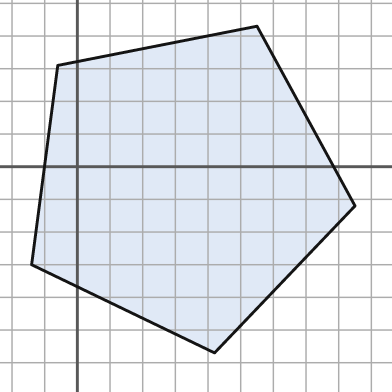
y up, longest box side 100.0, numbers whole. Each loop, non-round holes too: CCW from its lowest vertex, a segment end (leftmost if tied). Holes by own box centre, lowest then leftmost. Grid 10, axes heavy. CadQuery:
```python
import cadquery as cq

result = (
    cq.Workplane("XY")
    .moveTo(42.0, -57.0)
    .lineTo(85.0, -12.0)
    .lineTo(55.0, 43.0)
    .lineTo(-6.0, 31.0)
    .lineTo(-14.0, -30.0)
    .close()
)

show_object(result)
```